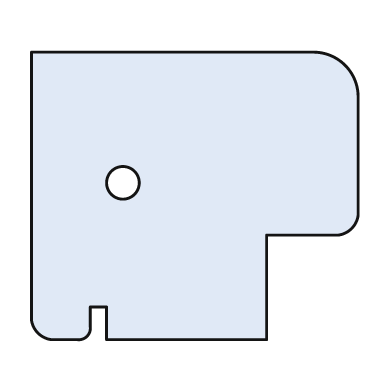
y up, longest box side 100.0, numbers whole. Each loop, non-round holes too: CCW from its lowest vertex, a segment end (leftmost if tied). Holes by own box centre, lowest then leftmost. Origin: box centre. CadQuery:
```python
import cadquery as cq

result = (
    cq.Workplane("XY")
    .moveTo(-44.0, -44.0)
    .lineTo(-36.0, -44.0)
    .threePointArc((-33.0, -43.0), (-32.0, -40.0))
    .lineTo(-32.0, -34.0)
    .lineTo(-27.0, -34.0)
    .lineTo(-27.0, -44.0)
    .lineTo(22.0, -44.0)
    .lineTo(22.0, -12.0)
    .lineTo(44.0, -12.0)
    .threePointArc((48.0, -10.0), (50.0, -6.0))
    .lineTo(50.0, 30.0)
    .threePointArc((46.0, 40.0), (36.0, 44.0))
    .lineTo(-50.0, 44.0)
    .lineTo(-50.0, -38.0)
    .threePointArc((-48.0, -42.0), (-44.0, -44.0))
    .close()
    .moveTo(-22.0, 4.0)
    .circle(5.0)
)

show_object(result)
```